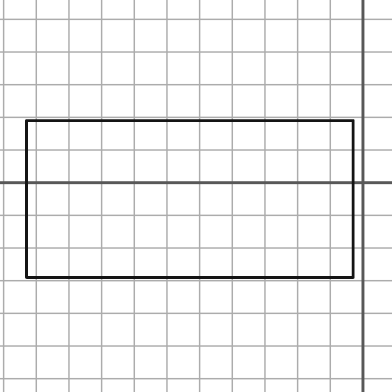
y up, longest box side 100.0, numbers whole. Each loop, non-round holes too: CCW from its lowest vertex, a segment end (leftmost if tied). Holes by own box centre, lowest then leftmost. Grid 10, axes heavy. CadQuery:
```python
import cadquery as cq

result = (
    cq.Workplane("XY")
    .moveTo(-103.0, -29.0)
    .lineTo(-3.0, -29.0)
    .lineTo(-3.0, 19.0)
    .lineTo(-103.0, 19.0)
    .close()
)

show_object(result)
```